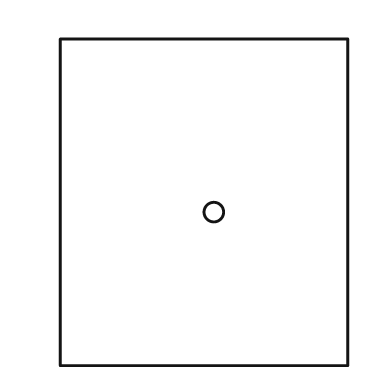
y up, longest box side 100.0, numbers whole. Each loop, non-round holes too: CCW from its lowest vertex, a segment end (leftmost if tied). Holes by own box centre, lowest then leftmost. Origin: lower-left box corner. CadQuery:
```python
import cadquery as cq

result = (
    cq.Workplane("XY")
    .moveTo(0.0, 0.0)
    .lineTo(88.0, 0.0)
    .lineTo(88.0, 100.0)
    .lineTo(0.0, 100.0)
    .close()
    .moveTo(47.0, 47.0)
    .circle(3.0)
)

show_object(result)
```